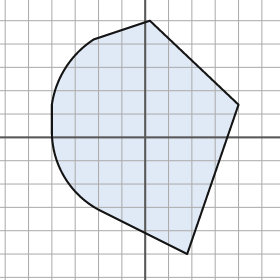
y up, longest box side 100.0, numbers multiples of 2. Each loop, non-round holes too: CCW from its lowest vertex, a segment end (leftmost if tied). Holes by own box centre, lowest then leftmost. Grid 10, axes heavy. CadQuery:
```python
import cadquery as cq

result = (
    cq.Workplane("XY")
    .moveTo(18.0, -50.0)
    .lineTo(40.0, 14.0)
    .lineTo(2.0, 50.0)
    .lineTo(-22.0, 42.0)
    .threePointArc((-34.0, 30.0), (-40.0, 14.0))
    .lineTo(-40.0, 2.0)
    .threePointArc((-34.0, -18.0), (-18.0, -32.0))
    .close()
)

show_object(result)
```